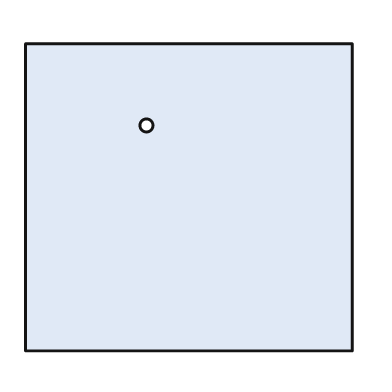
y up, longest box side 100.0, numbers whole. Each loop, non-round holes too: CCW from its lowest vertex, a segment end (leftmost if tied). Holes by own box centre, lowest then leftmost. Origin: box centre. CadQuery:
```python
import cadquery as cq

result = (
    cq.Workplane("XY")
    .moveTo(-50.0, -47.0)
    .lineTo(50.0, -47.0)
    .lineTo(50.0, 47.0)
    .lineTo(-50.0, 47.0)
    .close()
    .moveTo(-13.0, 22.0)
    .circle(2.0)
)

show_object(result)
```